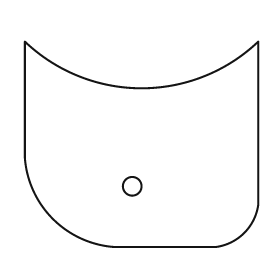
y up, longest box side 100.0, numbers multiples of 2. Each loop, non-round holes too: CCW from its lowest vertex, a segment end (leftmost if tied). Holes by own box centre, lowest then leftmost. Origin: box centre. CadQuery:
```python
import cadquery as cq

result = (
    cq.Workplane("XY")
    .moveTo(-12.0, -44.0)
    .lineTo(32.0, -44.0)
    .threePointArc((44.0, -38.0), (50.0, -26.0))
    .lineTo(50.0, 44.0)
    .threePointArc((0.0, 24.0), (-50.0, 44.0))
    .lineTo(-50.0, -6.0)
    .threePointArc((-38.0, -32.0), (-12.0, -44.0))
    .close()
    .moveTo(-4.0, -18.0)
    .circle(4.0)
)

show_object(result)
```